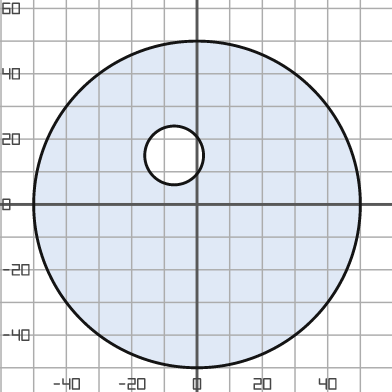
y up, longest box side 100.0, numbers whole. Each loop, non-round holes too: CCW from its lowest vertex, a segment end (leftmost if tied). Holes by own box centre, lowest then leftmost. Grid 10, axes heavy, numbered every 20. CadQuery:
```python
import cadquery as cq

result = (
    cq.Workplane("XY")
    .moveTo(0.0, 0.0)
    .circle(50.0)
    .moveTo(-7.0, 15.0)
    .circle(9.0)
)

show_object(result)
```